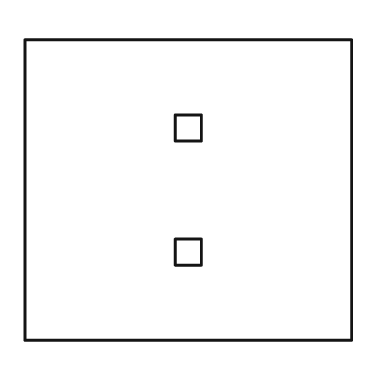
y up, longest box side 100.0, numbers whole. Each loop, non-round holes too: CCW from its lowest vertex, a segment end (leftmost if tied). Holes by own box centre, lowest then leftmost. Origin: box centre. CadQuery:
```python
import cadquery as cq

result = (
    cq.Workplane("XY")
    .moveTo(-50.0, -46.0)
    .lineTo(50.0, -46.0)
    .lineTo(50.0, 46.0)
    .lineTo(-50.0, 46.0)
    .close()
    .moveTo(-4.0, -23.0)
    .lineTo(4.0, -23.0)
    .lineTo(4.0, -15.0)
    .lineTo(-4.0, -15.0)
    .close()
    .moveTo(-4.0, 15.0)
    .lineTo(4.0, 15.0)
    .lineTo(4.0, 23.0)
    .lineTo(-4.0, 23.0)
    .close()
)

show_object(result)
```